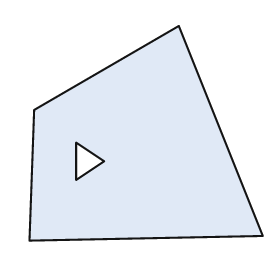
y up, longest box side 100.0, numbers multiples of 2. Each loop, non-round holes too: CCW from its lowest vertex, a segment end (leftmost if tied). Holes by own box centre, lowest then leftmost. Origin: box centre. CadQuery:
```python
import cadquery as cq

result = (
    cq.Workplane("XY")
    .moveTo(-50.0, -46.0)
    .lineTo(50.0, -44.0)
    .lineTo(14.0, 46.0)
    .lineTo(-48.0, 10.0)
    .close()
    .moveTo(-30.0, -20.0)
    .lineTo(-18.0, -12.0)
    .lineTo(-30.0, -4.0)
    .close()
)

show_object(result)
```